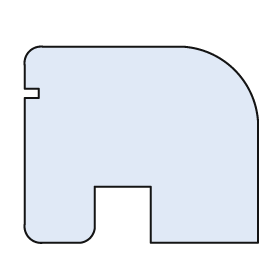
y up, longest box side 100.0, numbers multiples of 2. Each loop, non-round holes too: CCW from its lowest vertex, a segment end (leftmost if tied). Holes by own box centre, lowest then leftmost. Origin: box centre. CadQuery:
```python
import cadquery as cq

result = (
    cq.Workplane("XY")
    .moveTo(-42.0, -42.0)
    .lineTo(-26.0, -42.0)
    .threePointArc((-22.0, -40.0), (-20.0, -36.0))
    .lineTo(-20.0, -18.0)
    .lineTo(4.0, -18.0)
    .lineTo(4.0, -42.0)
    .lineTo(50.0, -42.0)
    .lineTo(50.0, 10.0)
    .threePointArc((40.0, 32.0), (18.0, 42.0))
    .lineTo(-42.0, 42.0)
    .threePointArc((-48.0, 40.0), (-50.0, 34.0))
    .lineTo(-50.0, 24.0)
    .lineTo(-44.0, 24.0)
    .lineTo(-44.0, 20.0)
    .lineTo(-50.0, 20.0)
    .lineTo(-50.0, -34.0)
    .threePointArc((-48.0, -40.0), (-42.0, -42.0))
    .close()
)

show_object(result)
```